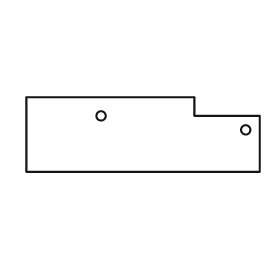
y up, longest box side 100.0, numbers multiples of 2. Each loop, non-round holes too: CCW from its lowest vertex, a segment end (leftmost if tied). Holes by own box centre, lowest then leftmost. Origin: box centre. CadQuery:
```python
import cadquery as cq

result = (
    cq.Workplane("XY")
    .moveTo(-50.0, -16.0)
    .lineTo(50.0, -16.0)
    .lineTo(50.0, 8.0)
    .lineTo(22.0, 8.0)
    .lineTo(22.0, 16.0)
    .lineTo(-50.0, 16.0)
    .close()
    .moveTo(44.0, 2.0)
    .circle(2.0)
    .moveTo(-18.0, 8.0)
    .circle(2.0)
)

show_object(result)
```